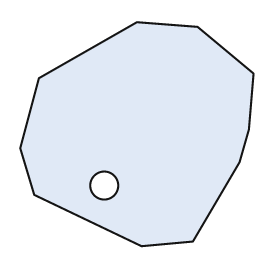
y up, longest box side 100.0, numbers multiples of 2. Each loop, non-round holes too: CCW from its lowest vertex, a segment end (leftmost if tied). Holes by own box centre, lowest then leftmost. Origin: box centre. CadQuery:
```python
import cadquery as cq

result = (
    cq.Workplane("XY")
    .moveTo(2.0, -48.0)
    .lineTo(24.0, -46.0)
    .lineTo(44.0, -12.0)
    .lineTo(48.0, 2.0)
    .lineTo(50.0, 26.0)
    .lineTo(26.0, 46.0)
    .lineTo(0.0, 48.0)
    .lineTo(-42.0, 24.0)
    .lineTo(-50.0, -6.0)
    .lineTo(-44.0, -26.0)
    .close()
    .moveTo(-14.0, -22.0)
    .circle(6.0)
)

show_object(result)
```